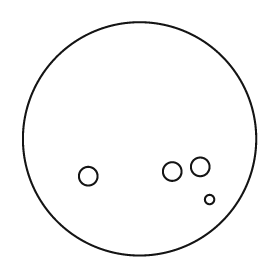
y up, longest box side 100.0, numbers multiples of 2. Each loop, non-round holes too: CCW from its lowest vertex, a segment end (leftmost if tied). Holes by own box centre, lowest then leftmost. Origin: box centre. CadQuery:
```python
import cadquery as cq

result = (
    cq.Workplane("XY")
    .moveTo(0.0, 0.0)
    .circle(50.0)
    .moveTo(30.0, -26.0)
    .circle(2.0)
    .moveTo(-22.0, -16.0)
    .circle(4.0)
    .moveTo(14.0, -14.0)
    .circle(4.0)
    .moveTo(26.0, -12.0)
    .circle(4.0)
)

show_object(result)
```